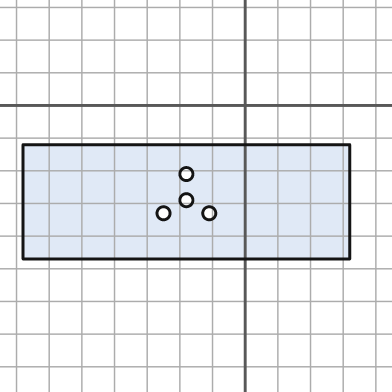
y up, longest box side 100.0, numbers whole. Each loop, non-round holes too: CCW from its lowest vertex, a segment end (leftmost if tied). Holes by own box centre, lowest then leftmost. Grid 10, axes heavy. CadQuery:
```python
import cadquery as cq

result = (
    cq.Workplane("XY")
    .moveTo(-68.0, -47.0)
    .lineTo(32.0, -47.0)
    .lineTo(32.0, -12.0)
    .lineTo(-68.0, -12.0)
    .close()
    .moveTo(-25.0, -33.0)
    .circle(2.0)
    .moveTo(-11.0, -33.0)
    .circle(2.0)
    .moveTo(-18.0, -29.0)
    .circle(2.0)
    .moveTo(-18.0, -21.0)
    .circle(2.0)
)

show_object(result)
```